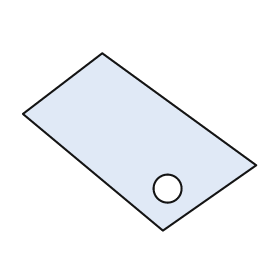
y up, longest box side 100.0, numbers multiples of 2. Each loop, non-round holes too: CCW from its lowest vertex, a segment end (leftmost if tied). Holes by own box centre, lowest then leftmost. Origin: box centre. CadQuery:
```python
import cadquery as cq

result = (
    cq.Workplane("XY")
    .moveTo(10.0, -38.0)
    .lineTo(50.0, -10.0)
    .lineTo(-16.0, 38.0)
    .lineTo(-50.0, 12.0)
    .close()
    .moveTo(12.0, -20.0)
    .circle(6.0)
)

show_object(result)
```